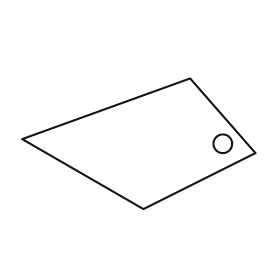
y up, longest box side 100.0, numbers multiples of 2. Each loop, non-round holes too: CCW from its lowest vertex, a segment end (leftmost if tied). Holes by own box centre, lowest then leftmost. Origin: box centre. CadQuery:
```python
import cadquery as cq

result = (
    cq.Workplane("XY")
    .moveTo(2.0, -28.0)
    .lineTo(50.0, -4.0)
    .lineTo(22.0, 28.0)
    .lineTo(-50.0, 2.0)
    .close()
    .moveTo(36.0, 0.0)
    .circle(4.0)
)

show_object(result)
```